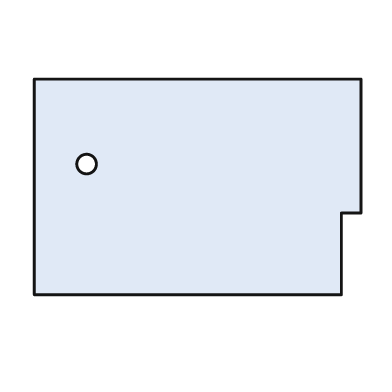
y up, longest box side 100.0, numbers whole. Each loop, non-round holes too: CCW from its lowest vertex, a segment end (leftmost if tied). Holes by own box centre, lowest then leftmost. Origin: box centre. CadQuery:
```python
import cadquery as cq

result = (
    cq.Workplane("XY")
    .moveTo(-50.0, -33.0)
    .lineTo(44.0, -33.0)
    .lineTo(44.0, -8.0)
    .lineTo(50.0, -8.0)
    .lineTo(50.0, 33.0)
    .lineTo(-50.0, 33.0)
    .close()
    .moveTo(-34.0, 7.0)
    .circle(3.0)
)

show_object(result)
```